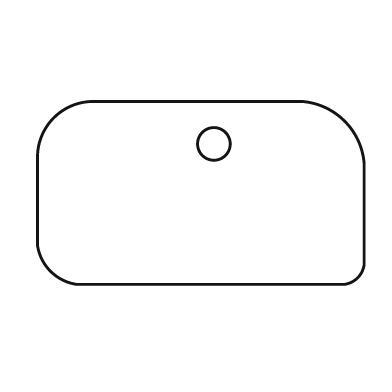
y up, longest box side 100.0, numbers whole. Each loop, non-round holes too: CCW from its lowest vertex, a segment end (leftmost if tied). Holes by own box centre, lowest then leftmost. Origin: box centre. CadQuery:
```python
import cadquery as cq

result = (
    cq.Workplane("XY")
    .moveTo(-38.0, -28.0)
    .lineTo(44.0, -28.0)
    .threePointArc((48.0, -26.0), (50.0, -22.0))
    .lineTo(50.0, 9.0)
    .threePointArc((44.0, 22.0), (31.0, 28.0))
    .lineTo(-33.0, 28.0)
    .threePointArc((-45.0, 23.0), (-50.0, 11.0))
    .lineTo(-50.0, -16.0)
    .threePointArc((-46.0, -24.0), (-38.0, -28.0))
    .close()
    .moveTo(4.0, 15.0)
    .circle(5.0)
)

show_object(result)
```